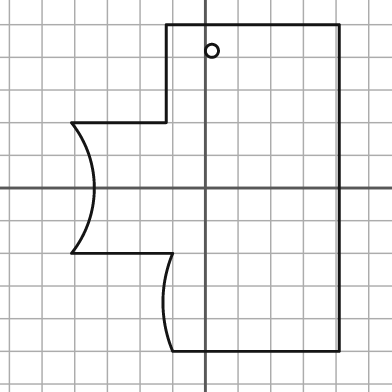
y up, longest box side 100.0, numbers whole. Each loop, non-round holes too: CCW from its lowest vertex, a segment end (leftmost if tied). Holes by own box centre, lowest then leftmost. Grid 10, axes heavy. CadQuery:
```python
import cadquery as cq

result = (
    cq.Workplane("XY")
    .moveTo(-10.0, -50.0)
    .lineTo(41.0, -50.0)
    .lineTo(41.0, 50.0)
    .lineTo(-12.0, 50.0)
    .lineTo(-12.0, 20.0)
    .lineTo(-41.0, 20.0)
    .threePointArc((-34.0, 0.0), (-41.0, -20.0))
    .lineTo(-10.0, -20.0)
    .threePointArc((-13.0, -35.0), (-10.0, -50.0))
    .close()
    .moveTo(2.0, 42.0)
    .circle(2.0)
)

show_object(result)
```